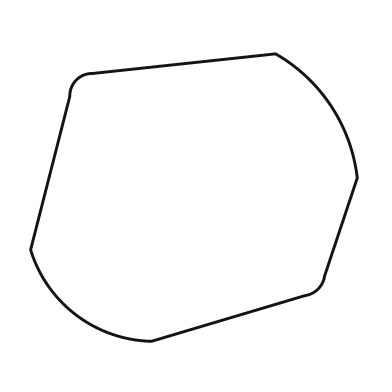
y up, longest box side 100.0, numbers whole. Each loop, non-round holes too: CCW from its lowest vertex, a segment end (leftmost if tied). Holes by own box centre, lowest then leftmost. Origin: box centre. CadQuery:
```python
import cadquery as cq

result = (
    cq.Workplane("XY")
    .moveTo(-13.0, -44.0)
    .lineTo(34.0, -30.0)
    .threePointArc((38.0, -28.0), (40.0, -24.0))
    .lineTo(50.0, 6.0)
    .threePointArc((42.0, 28.0), (25.0, 44.0))
    .lineTo(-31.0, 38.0)
    .threePointArc((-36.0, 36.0), (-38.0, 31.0))
    .lineTo(-50.0, -16.0)
    .threePointArc((-36.0, -36.0), (-13.0, -44.0))
    .close()
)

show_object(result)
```